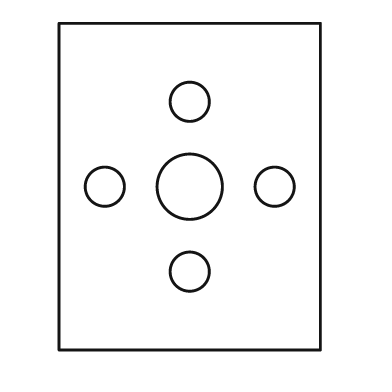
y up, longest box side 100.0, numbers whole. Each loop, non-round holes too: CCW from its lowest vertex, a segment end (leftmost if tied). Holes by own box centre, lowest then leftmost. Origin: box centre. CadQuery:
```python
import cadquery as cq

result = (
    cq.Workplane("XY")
    .moveTo(-40.0, -50.0)
    .lineTo(40.0, -50.0)
    .lineTo(40.0, 50.0)
    .lineTo(-40.0, 50.0)
    .close()
    .moveTo(0.0, -26.0)
    .circle(6.0)
    .moveTo(-26.0, 0.0)
    .circle(6.0)
    .moveTo(0.0, 0.0)
    .circle(10.0)
    .moveTo(26.0, 0.0)
    .circle(6.0)
    .moveTo(0.0, 26.0)
    .circle(6.0)
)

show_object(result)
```